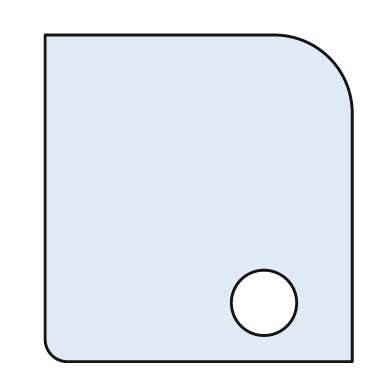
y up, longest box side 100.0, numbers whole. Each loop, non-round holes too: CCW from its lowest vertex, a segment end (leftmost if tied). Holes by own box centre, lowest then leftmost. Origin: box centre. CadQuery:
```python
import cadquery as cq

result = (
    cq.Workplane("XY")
    .moveTo(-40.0, -50.0)
    .lineTo(47.0, -50.0)
    .lineTo(47.0, 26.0)
    .threePointArc((40.0, 43.0), (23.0, 50.0))
    .lineTo(-47.0, 50.0)
    .lineTo(-47.0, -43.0)
    .threePointArc((-45.0, -48.0), (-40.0, -50.0))
    .close()
    .moveTo(20.0, -32.0)
    .circle(10.0)
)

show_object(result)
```